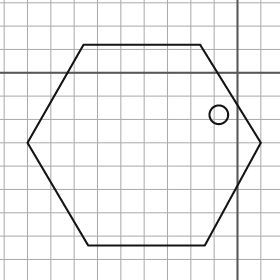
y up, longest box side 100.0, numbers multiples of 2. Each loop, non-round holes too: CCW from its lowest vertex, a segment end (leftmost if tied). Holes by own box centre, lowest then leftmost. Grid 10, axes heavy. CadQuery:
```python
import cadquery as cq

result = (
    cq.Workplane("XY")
    .moveTo(-64.0, -74.0)
    .lineTo(-14.0, -74.0)
    .lineTo(10.0, -30.0)
    .lineTo(-16.0, 12.0)
    .lineTo(-66.0, 12.0)
    .lineTo(-90.0, -30.0)
    .close()
    .moveTo(-8.0, -18.0)
    .circle(4.0)
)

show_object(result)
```